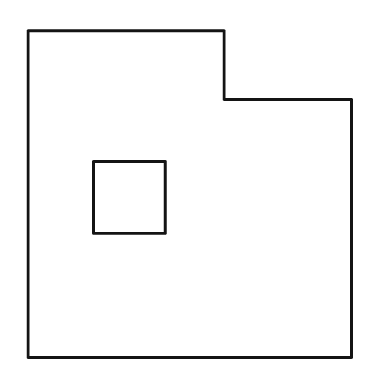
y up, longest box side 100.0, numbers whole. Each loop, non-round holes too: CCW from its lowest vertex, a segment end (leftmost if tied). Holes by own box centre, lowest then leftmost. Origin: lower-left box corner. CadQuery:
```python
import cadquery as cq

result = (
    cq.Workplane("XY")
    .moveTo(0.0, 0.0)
    .lineTo(99.0, 0.0)
    .lineTo(99.0, 79.0)
    .lineTo(60.0, 79.0)
    .lineTo(60.0, 100.0)
    .lineTo(0.0, 100.0)
    .close()
    .moveTo(20.0, 38.0)
    .lineTo(42.0, 38.0)
    .lineTo(42.0, 60.0)
    .lineTo(20.0, 60.0)
    .close()
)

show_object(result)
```